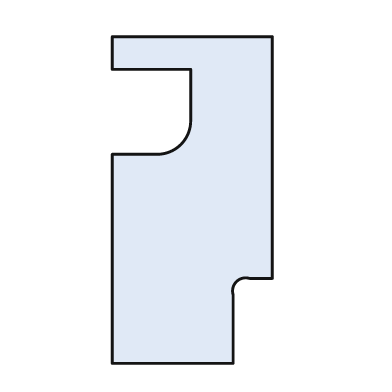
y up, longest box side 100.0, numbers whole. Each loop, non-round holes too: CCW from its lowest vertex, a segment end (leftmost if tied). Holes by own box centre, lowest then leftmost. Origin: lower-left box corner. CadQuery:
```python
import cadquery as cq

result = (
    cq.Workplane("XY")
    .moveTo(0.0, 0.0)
    .lineTo(37.0, 0.0)
    .lineTo(37.0, 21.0)
    .threePointArc((38.0, 25.0), (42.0, 26.0))
    .lineTo(49.0, 26.0)
    .lineTo(49.0, 100.0)
    .lineTo(0.0, 100.0)
    .lineTo(0.0, 90.0)
    .lineTo(24.0, 90.0)
    .lineTo(24.0, 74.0)
    .threePointArc((21.0, 67.0), (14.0, 64.0))
    .lineTo(0.0, 64.0)
    .close()
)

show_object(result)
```